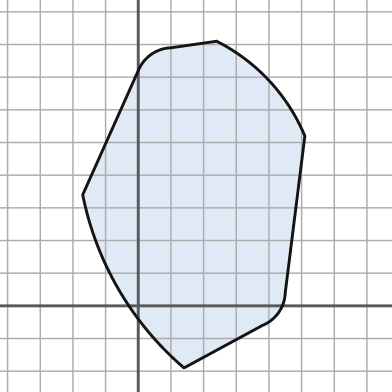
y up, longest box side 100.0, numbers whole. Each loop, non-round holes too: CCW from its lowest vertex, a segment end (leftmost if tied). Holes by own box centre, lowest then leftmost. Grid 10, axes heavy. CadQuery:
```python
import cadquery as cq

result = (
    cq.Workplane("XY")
    .moveTo(14.0, -19.0)
    .lineTo(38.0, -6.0)
    .threePointArc((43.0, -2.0), (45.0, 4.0))
    .lineTo(51.0, 52.0)
    .threePointArc((40.0, 69.0), (24.0, 81.0))
    .lineTo(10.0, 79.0)
    .threePointArc((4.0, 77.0), (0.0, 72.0))
    .lineTo(-17.0, 34.0)
    .threePointArc((-6.0, 5.0), (14.0, -19.0))
    .close()
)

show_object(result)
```